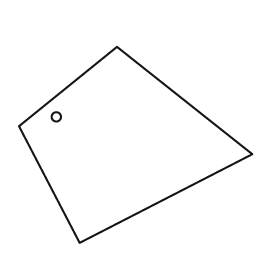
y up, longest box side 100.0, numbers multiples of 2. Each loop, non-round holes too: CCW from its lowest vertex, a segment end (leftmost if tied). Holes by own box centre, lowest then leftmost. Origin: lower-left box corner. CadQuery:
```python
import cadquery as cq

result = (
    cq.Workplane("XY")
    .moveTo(26.0, 0.0)
    .lineTo(100.0, 38.0)
    .lineTo(42.0, 84.0)
    .lineTo(0.0, 50.0)
    .close()
    .moveTo(16.0, 54.0)
    .circle(2.0)
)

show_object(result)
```